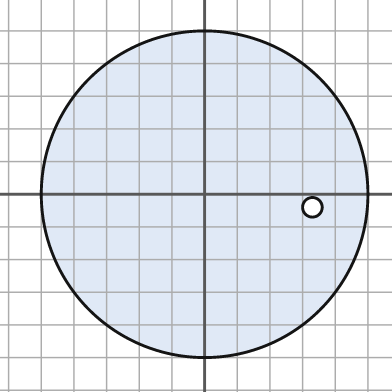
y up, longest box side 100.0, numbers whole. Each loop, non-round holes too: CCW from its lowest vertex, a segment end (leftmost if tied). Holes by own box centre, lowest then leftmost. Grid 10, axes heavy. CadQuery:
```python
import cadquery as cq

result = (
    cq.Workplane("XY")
    .moveTo(0.0, 0.0)
    .circle(50.0)
    .moveTo(33.0, -4.0)
    .circle(3.0)
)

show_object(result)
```